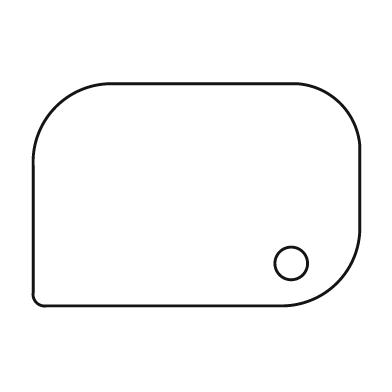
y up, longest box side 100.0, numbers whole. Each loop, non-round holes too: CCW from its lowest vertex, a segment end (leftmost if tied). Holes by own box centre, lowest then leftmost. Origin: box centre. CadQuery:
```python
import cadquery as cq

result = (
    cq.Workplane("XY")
    .moveTo(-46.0, -34.0)
    .lineTo(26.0, -34.0)
    .threePointArc((43.0, -27.0), (50.0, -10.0))
    .lineTo(50.0, 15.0)
    .threePointArc((44.0, 28.0), (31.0, 34.0))
    .lineTo(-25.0, 34.0)
    .threePointArc((-43.0, 27.0), (-50.0, 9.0))
    .lineTo(-50.0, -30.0)
    .threePointArc((-49.0, -33.0), (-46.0, -34.0))
    .close()
    .moveTo(29.0, -21.0)
    .circle(5.0)
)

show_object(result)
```